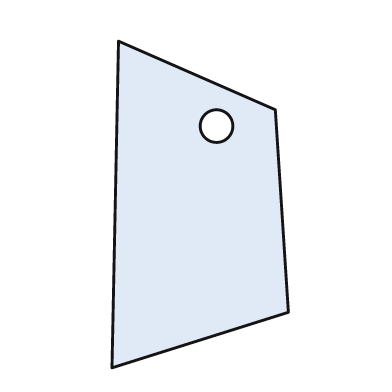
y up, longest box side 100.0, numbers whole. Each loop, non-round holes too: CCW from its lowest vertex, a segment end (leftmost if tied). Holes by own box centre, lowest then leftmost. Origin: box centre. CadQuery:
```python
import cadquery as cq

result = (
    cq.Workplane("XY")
    .moveTo(-27.0, -50.0)
    .lineTo(27.0, -33.0)
    .lineTo(23.0, 29.0)
    .lineTo(-25.0, 50.0)
    .close()
    .moveTo(5.0, 24.0)
    .circle(5.0)
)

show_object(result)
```